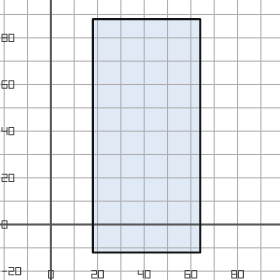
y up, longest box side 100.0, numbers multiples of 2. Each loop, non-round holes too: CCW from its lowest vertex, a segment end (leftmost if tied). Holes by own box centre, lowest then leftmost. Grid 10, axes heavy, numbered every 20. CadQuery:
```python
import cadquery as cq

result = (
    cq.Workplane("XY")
    .moveTo(18.0, -12.0)
    .lineTo(64.0, -12.0)
    .lineTo(64.0, 88.0)
    .lineTo(18.0, 88.0)
    .close()
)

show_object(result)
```